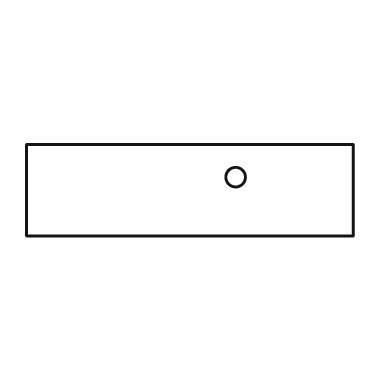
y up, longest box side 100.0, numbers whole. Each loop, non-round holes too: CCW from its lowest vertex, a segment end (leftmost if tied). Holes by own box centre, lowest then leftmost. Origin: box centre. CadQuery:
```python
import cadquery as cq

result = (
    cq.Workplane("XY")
    .moveTo(-50.0, -14.0)
    .lineTo(50.0, -14.0)
    .lineTo(50.0, 14.0)
    .lineTo(-50.0, 14.0)
    .close()
    .moveTo(14.0, 4.0)
    .circle(3.0)
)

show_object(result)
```